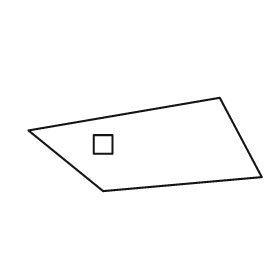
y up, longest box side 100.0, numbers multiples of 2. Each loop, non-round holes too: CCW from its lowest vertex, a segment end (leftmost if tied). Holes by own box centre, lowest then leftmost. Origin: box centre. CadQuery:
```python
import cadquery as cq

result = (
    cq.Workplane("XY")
    .moveTo(-18.0, -20.0)
    .lineTo(50.0, -14.0)
    .lineTo(32.0, 20.0)
    .lineTo(-50.0, 6.0)
    .close()
    .moveTo(-22.0, -4.0)
    .lineTo(-14.0, -4.0)
    .lineTo(-14.0, 4.0)
    .lineTo(-22.0, 4.0)
    .close()
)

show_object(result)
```